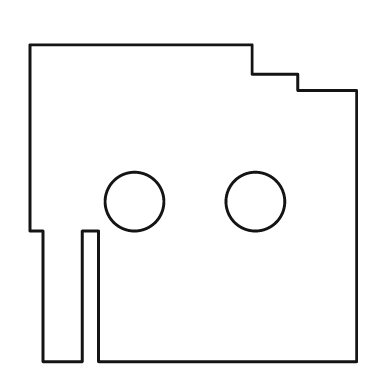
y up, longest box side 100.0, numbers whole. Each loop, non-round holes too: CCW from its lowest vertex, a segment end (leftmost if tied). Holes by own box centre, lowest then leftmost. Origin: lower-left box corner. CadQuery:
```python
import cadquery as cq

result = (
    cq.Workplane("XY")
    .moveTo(4.0, 0.0)
    .lineTo(16.0, 0.0)
    .lineTo(16.0, 40.0)
    .lineTo(21.0, 40.0)
    .lineTo(21.0, 0.0)
    .lineTo(100.0, 0.0)
    .lineTo(100.0, 83.0)
    .lineTo(82.0, 83.0)
    .lineTo(82.0, 88.0)
    .lineTo(68.0, 88.0)
    .lineTo(68.0, 97.0)
    .lineTo(0.0, 97.0)
    .lineTo(0.0, 40.0)
    .lineTo(4.0, 40.0)
    .close()
    .moveTo(32.0, 49.0)
    .circle(9.0)
    .moveTo(69.0, 49.0)
    .circle(9.0)
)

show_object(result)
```